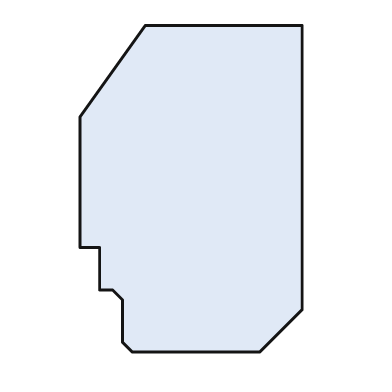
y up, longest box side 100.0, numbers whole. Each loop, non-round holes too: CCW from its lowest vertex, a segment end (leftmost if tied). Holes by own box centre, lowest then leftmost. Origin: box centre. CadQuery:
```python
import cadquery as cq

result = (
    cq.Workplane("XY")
    .moveTo(-18.0, -50.0)
    .lineTo(21.0, -50.0)
    .lineTo(34.0, -37.0)
    .lineTo(34.0, 50.0)
    .lineTo(-14.0, 50.0)
    .lineTo(-34.0, 22.0)
    .lineTo(-34.0, -18.0)
    .lineTo(-28.0, -18.0)
    .lineTo(-28.0, -31.0)
    .lineTo(-24.0, -31.0)
    .lineTo(-21.0, -34.0)
    .lineTo(-21.0, -47.0)
    .close()
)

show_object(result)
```